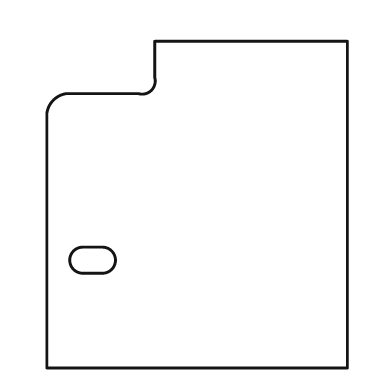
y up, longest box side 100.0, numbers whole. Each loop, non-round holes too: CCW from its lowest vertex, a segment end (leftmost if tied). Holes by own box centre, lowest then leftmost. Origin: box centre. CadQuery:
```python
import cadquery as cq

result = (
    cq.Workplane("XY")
    .moveTo(-46.0, -50.0)
    .lineTo(46.0, -50.0)
    .lineTo(46.0, 50.0)
    .lineTo(-13.0, 50.0)
    .lineTo(-13.0, 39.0)
    .threePointArc((-14.0, 35.0), (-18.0, 34.0))
    .lineTo(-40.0, 34.0)
    .threePointArc((-44.0, 32.0), (-46.0, 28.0))
    .close()
    .moveTo(-35.0, -21.0)
    .lineTo(-29.0, -21.0)
    .threePointArc((-25.0, -17.0), (-29.0, -13.0))
    .lineTo(-35.0, -13.0)
    .threePointArc((-39.0, -17.0), (-35.0, -21.0))
    .close()
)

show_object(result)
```